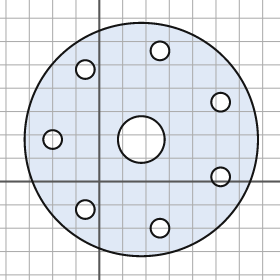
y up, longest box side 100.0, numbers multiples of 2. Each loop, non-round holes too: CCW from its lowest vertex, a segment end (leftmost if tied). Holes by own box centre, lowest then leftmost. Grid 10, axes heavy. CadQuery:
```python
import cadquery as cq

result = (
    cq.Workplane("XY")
    .moveTo(18.0, 18.0)
    .circle(50.0)
    .moveTo(26.0, -20.0)
    .circle(4.0)
    .moveTo(-6.0, -12.0)
    .circle(4.0)
    .moveTo(52.0, 2.0)
    .circle(4.0)
    .moveTo(-20.0, 18.0)
    .circle(4.0)
    .moveTo(18.0, 18.0)
    .circle(10.0)
    .moveTo(52.0, 34.0)
    .circle(4.0)
    .moveTo(-6.0, 48.0)
    .circle(4.0)
    .moveTo(26.0, 56.0)
    .circle(4.0)
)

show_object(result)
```